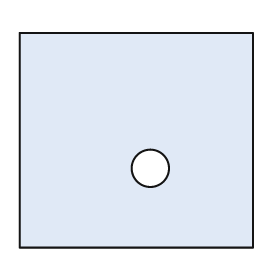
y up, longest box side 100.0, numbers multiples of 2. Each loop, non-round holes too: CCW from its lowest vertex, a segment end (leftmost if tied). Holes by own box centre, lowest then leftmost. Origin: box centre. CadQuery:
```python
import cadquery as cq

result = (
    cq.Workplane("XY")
    .moveTo(-50.0, -46.0)
    .lineTo(50.0, -46.0)
    .lineTo(50.0, 46.0)
    .lineTo(-50.0, 46.0)
    .close()
    .moveTo(6.0, -12.0)
    .circle(8.0)
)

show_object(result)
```